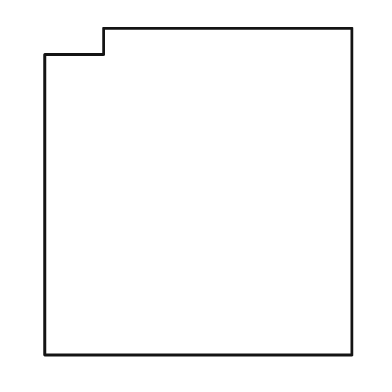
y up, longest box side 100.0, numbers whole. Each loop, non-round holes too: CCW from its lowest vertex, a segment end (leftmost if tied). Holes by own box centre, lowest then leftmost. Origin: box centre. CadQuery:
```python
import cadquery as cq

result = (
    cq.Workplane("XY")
    .moveTo(-47.0, -50.0)
    .lineTo(47.0, -50.0)
    .lineTo(47.0, 50.0)
    .lineTo(-29.0, 50.0)
    .lineTo(-29.0, 42.0)
    .lineTo(-47.0, 42.0)
    .close()
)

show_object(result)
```